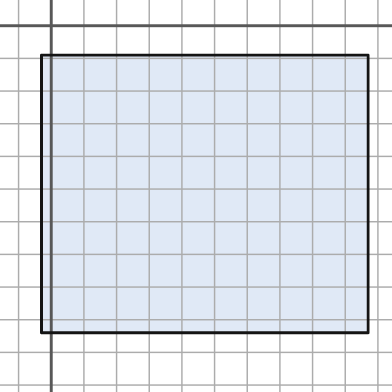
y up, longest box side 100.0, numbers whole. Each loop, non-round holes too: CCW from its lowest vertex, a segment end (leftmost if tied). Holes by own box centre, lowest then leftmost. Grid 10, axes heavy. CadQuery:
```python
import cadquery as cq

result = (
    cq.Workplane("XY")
    .moveTo(-3.0, -94.0)
    .lineTo(97.0, -94.0)
    .lineTo(97.0, -9.0)
    .lineTo(-3.0, -9.0)
    .close()
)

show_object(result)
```